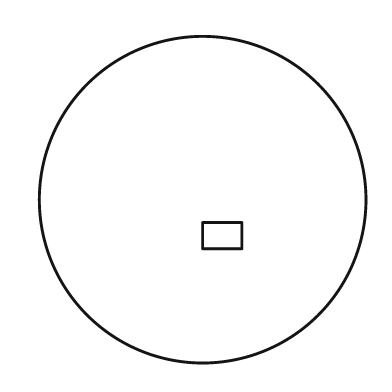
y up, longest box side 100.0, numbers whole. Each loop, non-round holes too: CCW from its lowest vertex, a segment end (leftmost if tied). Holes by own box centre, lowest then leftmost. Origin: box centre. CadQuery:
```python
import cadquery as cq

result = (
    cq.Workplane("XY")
    .moveTo(0.0, 0.0)
    .circle(50.0)
    .moveTo(0.0, -15.0)
    .lineTo(12.0, -15.0)
    .lineTo(12.0, -7.0)
    .lineTo(0.0, -7.0)
    .close()
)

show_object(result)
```